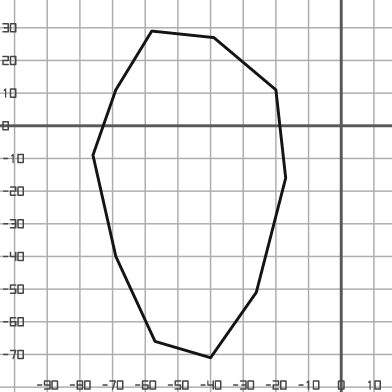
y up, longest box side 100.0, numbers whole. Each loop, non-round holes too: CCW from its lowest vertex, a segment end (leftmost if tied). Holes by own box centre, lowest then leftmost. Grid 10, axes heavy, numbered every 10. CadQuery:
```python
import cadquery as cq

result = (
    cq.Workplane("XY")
    .moveTo(-40.0, -71.0)
    .lineTo(-26.0, -51.0)
    .lineTo(-17.0, -16.0)
    .lineTo(-20.0, 11.0)
    .lineTo(-39.0, 27.0)
    .lineTo(-58.0, 29.0)
    .lineTo(-69.0, 11.0)
    .lineTo(-76.0, -9.0)
    .lineTo(-69.0, -40.0)
    .lineTo(-57.0, -66.0)
    .close()
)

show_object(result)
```